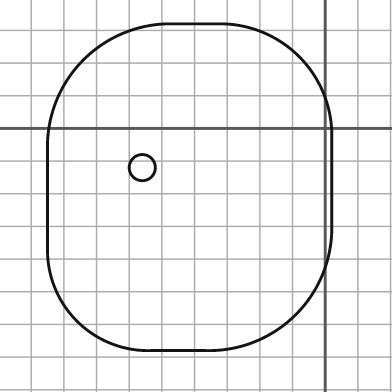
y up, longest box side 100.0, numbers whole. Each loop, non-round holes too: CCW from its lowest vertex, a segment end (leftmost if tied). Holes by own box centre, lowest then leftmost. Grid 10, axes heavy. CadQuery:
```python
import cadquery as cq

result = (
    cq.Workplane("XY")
    .moveTo(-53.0, -68.0)
    .lineTo(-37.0, -68.0)
    .threePointArc((-9.0, -57.0), (2.0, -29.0))
    .lineTo(2.0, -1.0)
    .threePointArc((-8.0, 22.0), (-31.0, 32.0))
    .lineTo(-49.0, 32.0)
    .threePointArc((-74.0, 21.0), (-85.0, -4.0))
    .lineTo(-85.0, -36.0)
    .threePointArc((-76.0, -59.0), (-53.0, -68.0))
    .close()
    .moveTo(-56.0, -12.0)
    .circle(4.0)
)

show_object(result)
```